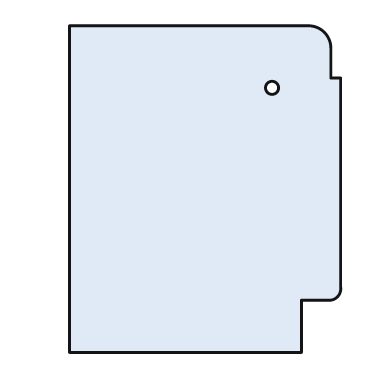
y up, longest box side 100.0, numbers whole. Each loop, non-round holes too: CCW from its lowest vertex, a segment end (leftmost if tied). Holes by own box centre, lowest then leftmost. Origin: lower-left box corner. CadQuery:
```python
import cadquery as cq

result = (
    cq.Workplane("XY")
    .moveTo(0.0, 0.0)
    .lineTo(71.0, 0.0)
    .lineTo(71.0, 16.0)
    .lineTo(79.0, 16.0)
    .threePointArc((82.0, 17.0), (83.0, 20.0))
    .lineTo(83.0, 84.0)
    .lineTo(80.0, 84.0)
    .lineTo(80.0, 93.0)
    .threePointArc((78.0, 98.0), (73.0, 100.0))
    .lineTo(0.0, 100.0)
    .close()
    .moveTo(62.0, 81.0)
    .circle(2.0)
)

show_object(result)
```